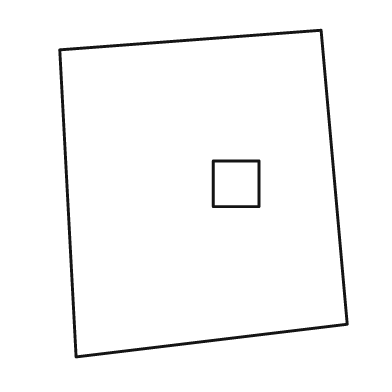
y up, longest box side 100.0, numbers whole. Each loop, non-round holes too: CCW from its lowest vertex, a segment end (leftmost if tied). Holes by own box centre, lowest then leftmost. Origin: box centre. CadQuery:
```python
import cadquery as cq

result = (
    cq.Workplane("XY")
    .moveTo(-39.0, -50.0)
    .lineTo(44.0, -40.0)
    .lineTo(36.0, 50.0)
    .lineTo(-44.0, 44.0)
    .close()
    .moveTo(3.0, -4.0)
    .lineTo(17.0, -4.0)
    .lineTo(17.0, 10.0)
    .lineTo(3.0, 10.0)
    .close()
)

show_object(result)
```